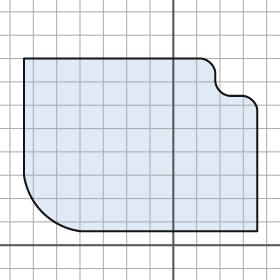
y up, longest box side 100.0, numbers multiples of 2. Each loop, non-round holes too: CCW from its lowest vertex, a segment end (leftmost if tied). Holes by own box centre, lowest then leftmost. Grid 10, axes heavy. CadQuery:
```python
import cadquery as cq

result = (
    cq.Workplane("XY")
    .moveTo(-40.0, 6.0)
    .lineTo(36.0, 6.0)
    .lineTo(36.0, 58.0)
    .threePointArc((34.0, 62.0), (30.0, 64.0))
    .lineTo(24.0, 64.0)
    .threePointArc((20.0, 66.0), (18.0, 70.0))
    .lineTo(18.0, 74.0)
    .threePointArc((16.0, 78.0), (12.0, 80.0))
    .lineTo(-64.0, 80.0)
    .lineTo(-64.0, 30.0)
    .threePointArc((-56.0, 14.0), (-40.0, 6.0))
    .close()
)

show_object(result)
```